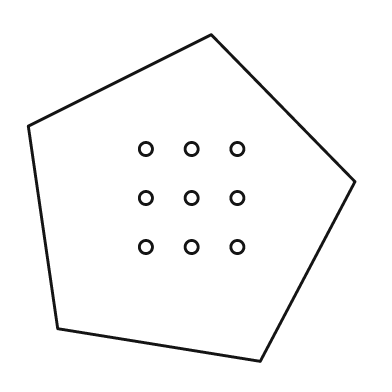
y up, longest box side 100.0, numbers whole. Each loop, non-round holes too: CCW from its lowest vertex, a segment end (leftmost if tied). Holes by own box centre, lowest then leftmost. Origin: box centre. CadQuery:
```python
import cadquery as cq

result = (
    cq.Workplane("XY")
    .moveTo(21.0, -50.0)
    .lineTo(50.0, 5.0)
    .lineTo(6.0, 50.0)
    .lineTo(-50.0, 22.0)
    .lineTo(-41.0, -40.0)
    .close()
    .moveTo(-14.0, -15.0)
    .circle(2.0)
    .moveTo(0.0, -15.0)
    .circle(2.0)
    .moveTo(14.0, -15.0)
    .circle(2.0)
    .moveTo(-14.0, 0.0)
    .circle(2.0)
    .moveTo(0.0, 0.0)
    .circle(2.0)
    .moveTo(14.0, 0.0)
    .circle(2.0)
    .moveTo(-14.0, 15.0)
    .circle(2.0)
    .moveTo(0.0, 15.0)
    .circle(2.0)
    .moveTo(14.0, 15.0)
    .circle(2.0)
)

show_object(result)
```